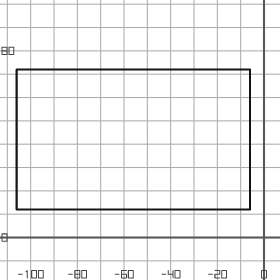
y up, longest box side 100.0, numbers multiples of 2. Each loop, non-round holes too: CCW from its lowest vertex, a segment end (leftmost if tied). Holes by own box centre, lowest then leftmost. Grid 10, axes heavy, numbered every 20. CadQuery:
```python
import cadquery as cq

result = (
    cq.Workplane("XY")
    .moveTo(-106.0, 12.0)
    .lineTo(-6.0, 12.0)
    .lineTo(-6.0, 72.0)
    .lineTo(-106.0, 72.0)
    .close()
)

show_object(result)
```